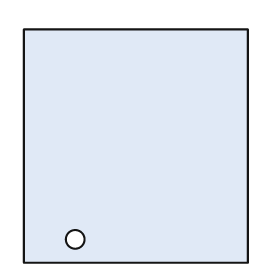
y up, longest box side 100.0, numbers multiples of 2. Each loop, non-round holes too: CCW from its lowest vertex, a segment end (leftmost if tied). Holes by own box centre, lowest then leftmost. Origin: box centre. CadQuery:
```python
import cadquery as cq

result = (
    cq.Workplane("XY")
    .moveTo(-48.0, -50.0)
    .lineTo(48.0, -50.0)
    .lineTo(48.0, 50.0)
    .lineTo(-48.0, 50.0)
    .close()
    .moveTo(-26.0, -40.0)
    .circle(4.0)
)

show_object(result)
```